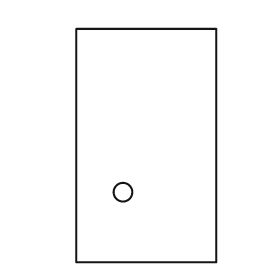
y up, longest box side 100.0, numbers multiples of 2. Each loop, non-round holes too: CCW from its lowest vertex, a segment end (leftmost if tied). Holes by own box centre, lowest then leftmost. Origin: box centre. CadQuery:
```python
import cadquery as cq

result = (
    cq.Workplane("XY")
    .moveTo(-30.0, -50.0)
    .lineTo(30.0, -50.0)
    .lineTo(30.0, 50.0)
    .lineTo(-30.0, 50.0)
    .close()
    .moveTo(-10.0, -20.0)
    .circle(4.0)
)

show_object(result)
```